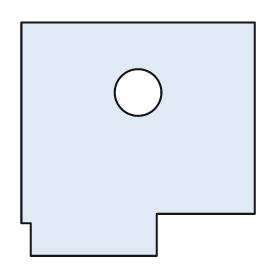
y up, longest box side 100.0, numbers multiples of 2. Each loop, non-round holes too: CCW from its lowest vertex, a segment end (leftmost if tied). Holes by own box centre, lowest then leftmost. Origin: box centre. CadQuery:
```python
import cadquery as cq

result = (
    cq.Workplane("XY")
    .moveTo(-46.0, -50.0)
    .lineTo(8.0, -50.0)
    .lineTo(8.0, -32.0)
    .lineTo(50.0, -32.0)
    .lineTo(50.0, 50.0)
    .lineTo(-50.0, 50.0)
    .lineTo(-50.0, -36.0)
    .lineTo(-46.0, -36.0)
    .close()
    .moveTo(0.0, 20.0)
    .circle(10.0)
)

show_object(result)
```